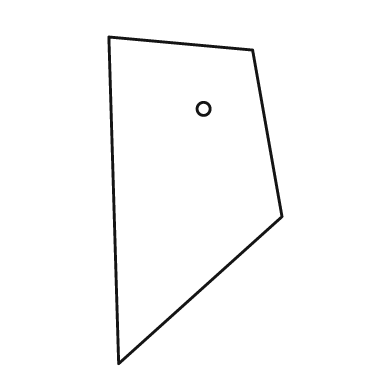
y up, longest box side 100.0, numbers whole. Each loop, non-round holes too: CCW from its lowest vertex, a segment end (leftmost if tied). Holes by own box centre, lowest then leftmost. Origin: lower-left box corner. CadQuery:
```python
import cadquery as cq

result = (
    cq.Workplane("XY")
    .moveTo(3.0, 0.0)
    .lineTo(53.0, 45.0)
    .lineTo(44.0, 96.0)
    .lineTo(0.0, 100.0)
    .close()
    .moveTo(29.0, 78.0)
    .circle(2.0)
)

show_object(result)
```